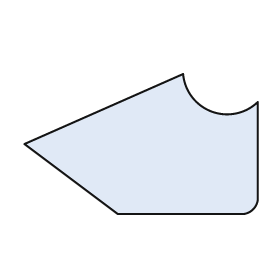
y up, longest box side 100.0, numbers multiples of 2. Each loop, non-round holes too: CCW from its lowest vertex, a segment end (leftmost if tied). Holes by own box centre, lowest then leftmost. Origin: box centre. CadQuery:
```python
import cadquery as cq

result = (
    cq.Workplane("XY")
    .moveTo(-10.0, -30.0)
    .lineTo(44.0, -30.0)
    .threePointArc((48.0, -28.0), (50.0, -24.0))
    .lineTo(50.0, 18.0)
    .threePointArc((30.0, 14.0), (18.0, 30.0))
    .lineTo(-50.0, 0.0)
    .close()
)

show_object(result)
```